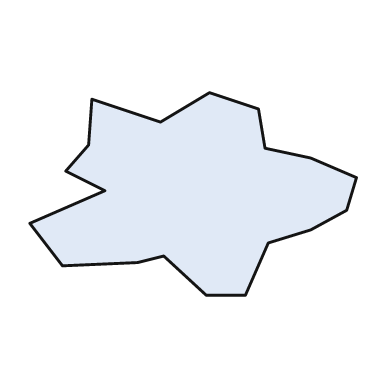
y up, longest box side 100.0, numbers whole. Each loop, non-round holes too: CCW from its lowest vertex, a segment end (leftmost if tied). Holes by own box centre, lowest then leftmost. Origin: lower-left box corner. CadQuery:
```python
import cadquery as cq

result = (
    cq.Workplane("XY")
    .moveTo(54.0, 0.0)
    .lineTo(66.0, 0.0)
    .lineTo(73.0, 16.0)
    .lineTo(86.0, 20.0)
    .lineTo(97.0, 26.0)
    .lineTo(100.0, 36.0)
    .lineTo(86.0, 42.0)
    .lineTo(72.0, 45.0)
    .lineTo(70.0, 57.0)
    .lineTo(55.0, 62.0)
    .lineTo(40.0, 53.0)
    .lineTo(19.0, 60.0)
    .lineTo(18.0, 46.0)
    .lineTo(11.0, 38.0)
    .lineTo(23.0, 32.0)
    .lineTo(0.0, 22.0)
    .lineTo(10.0, 9.0)
    .lineTo(33.0, 10.0)
    .lineTo(41.0, 12.0)
    .close()
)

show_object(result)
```